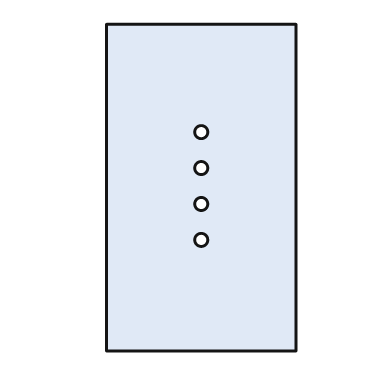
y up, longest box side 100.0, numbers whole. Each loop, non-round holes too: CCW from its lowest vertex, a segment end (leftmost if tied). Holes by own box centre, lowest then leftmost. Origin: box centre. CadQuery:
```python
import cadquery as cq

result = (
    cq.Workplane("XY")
    .moveTo(-29.0, -50.0)
    .lineTo(29.0, -50.0)
    .lineTo(29.0, 50.0)
    .lineTo(-29.0, 50.0)
    .close()
    .moveTo(0.0, -16.0)
    .circle(2.0)
    .moveTo(0.0, -5.0)
    .circle(2.0)
    .moveTo(0.0, 6.0)
    .circle(2.0)
    .moveTo(0.0, 17.0)
    .circle(2.0)
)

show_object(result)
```